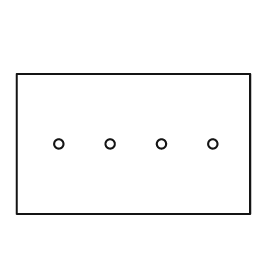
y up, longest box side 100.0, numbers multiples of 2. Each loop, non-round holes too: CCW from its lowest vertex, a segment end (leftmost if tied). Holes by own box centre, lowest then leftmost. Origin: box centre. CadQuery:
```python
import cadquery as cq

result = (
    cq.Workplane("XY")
    .moveTo(-50.0, -30.0)
    .lineTo(50.0, -30.0)
    .lineTo(50.0, 30.0)
    .lineTo(-50.0, 30.0)
    .close()
    .moveTo(-32.0, 0.0)
    .circle(2.0)
    .moveTo(-10.0, 0.0)
    .circle(2.0)
    .moveTo(12.0, 0.0)
    .circle(2.0)
    .moveTo(34.0, 0.0)
    .circle(2.0)
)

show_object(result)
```